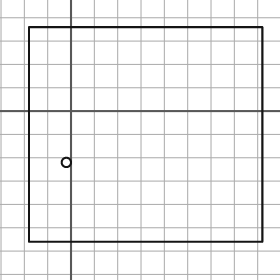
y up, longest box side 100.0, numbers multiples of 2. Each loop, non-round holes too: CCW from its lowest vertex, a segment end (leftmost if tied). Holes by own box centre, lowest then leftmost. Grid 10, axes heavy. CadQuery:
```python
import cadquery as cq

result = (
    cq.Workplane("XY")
    .moveTo(-18.0, -56.0)
    .lineTo(82.0, -56.0)
    .lineTo(82.0, 36.0)
    .lineTo(-18.0, 36.0)
    .close()
    .moveTo(-2.0, -22.0)
    .circle(2.0)
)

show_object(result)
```